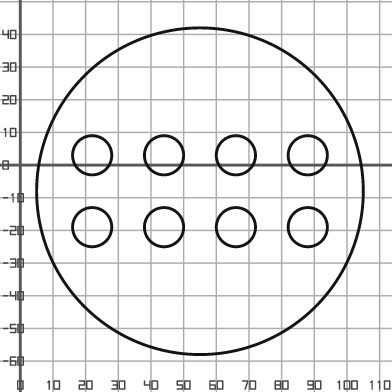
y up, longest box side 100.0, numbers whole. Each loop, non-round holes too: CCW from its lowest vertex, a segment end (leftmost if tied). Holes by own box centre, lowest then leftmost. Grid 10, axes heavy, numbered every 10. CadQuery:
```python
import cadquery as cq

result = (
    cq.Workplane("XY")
    .moveTo(55.0, -8.0)
    .circle(50.0)
    .moveTo(22.0, -19.0)
    .circle(6.0)
    .moveTo(44.0, -19.0)
    .circle(6.0)
    .moveTo(66.0, -19.0)
    .circle(6.0)
    .moveTo(88.0, -19.0)
    .circle(6.0)
    .moveTo(22.0, 3.0)
    .circle(6.0)
    .moveTo(44.0, 3.0)
    .circle(6.0)
    .moveTo(66.0, 3.0)
    .circle(6.0)
    .moveTo(88.0, 3.0)
    .circle(6.0)
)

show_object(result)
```